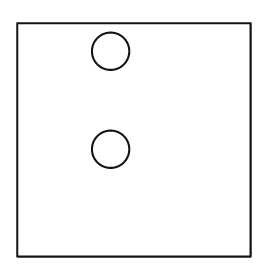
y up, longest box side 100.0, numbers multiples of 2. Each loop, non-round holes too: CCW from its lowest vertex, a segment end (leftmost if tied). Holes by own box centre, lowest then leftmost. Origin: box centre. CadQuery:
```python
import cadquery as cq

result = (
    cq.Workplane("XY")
    .moveTo(-50.0, -50.0)
    .lineTo(50.0, -50.0)
    .lineTo(50.0, 50.0)
    .lineTo(-50.0, 50.0)
    .close()
    .moveTo(-10.0, -4.0)
    .circle(8.0)
    .moveTo(-10.0, 38.0)
    .circle(8.0)
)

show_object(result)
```